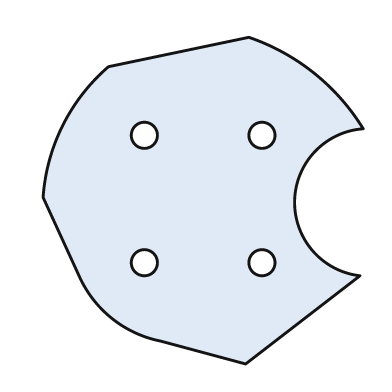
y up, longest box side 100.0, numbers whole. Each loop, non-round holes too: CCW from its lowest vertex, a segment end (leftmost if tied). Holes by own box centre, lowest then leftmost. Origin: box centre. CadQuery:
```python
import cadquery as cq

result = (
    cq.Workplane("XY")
    .moveTo(13.0, -50.0)
    .lineTo(48.0, -23.0)
    .threePointArc((28.0, 0.0), (49.0, 22.0))
    .threePointArc((34.0, 39.0), (14.0, 50.0))
    .lineTo(-29.0, 41.0)
    .threePointArc((-43.0, 23.0), (-49.0, 1.0))
    .lineTo(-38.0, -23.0)
    .threePointArc((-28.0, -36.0), (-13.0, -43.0))
    .close()
    .moveTo(-18.0, -19.0)
    .circle(4.0)
    .moveTo(18.0, -19.0)
    .circle(4.0)
    .moveTo(-18.0, 20.0)
    .circle(4.0)
    .moveTo(18.0, 20.0)
    .circle(4.0)
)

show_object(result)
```